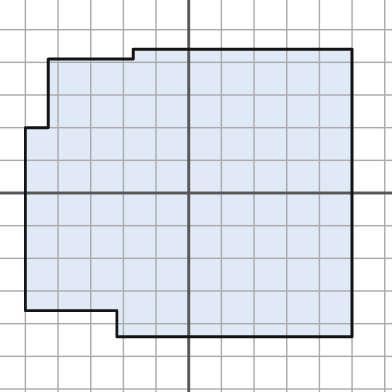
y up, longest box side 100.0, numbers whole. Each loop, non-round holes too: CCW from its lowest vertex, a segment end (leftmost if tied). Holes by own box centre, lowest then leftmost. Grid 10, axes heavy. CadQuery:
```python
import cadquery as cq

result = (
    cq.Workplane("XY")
    .moveTo(-22.0, -44.0)
    .lineTo(50.0, -44.0)
    .lineTo(50.0, 44.0)
    .lineTo(-17.0, 44.0)
    .lineTo(-17.0, 41.0)
    .lineTo(-43.0, 41.0)
    .lineTo(-43.0, 20.0)
    .lineTo(-50.0, 20.0)
    .lineTo(-50.0, -36.0)
    .lineTo(-22.0, -36.0)
    .close()
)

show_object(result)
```